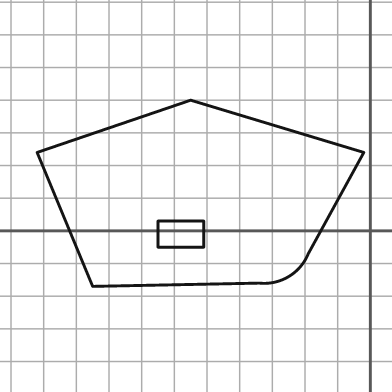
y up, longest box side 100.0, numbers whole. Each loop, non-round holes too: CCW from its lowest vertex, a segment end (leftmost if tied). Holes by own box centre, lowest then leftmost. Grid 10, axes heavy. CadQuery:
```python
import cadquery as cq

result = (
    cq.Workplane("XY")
    .moveTo(-85.0, -17.0)
    .lineTo(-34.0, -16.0)
    .threePointArc((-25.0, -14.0), (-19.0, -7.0))
    .lineTo(-2.0, 24.0)
    .lineTo(-55.0, 40.0)
    .lineTo(-102.0, 24.0)
    .close()
    .moveTo(-65.0, -5.0)
    .lineTo(-51.0, -5.0)
    .lineTo(-51.0, 3.0)
    .lineTo(-65.0, 3.0)
    .close()
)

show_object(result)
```